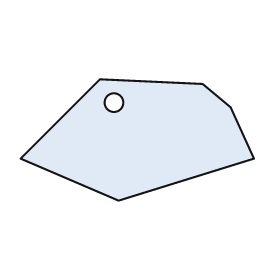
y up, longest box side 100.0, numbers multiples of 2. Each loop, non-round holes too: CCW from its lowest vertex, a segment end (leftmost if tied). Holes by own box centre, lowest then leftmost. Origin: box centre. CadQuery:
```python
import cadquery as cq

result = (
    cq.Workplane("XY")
    .moveTo(-8.0, -26.0)
    .lineTo(50.0, -8.0)
    .lineTo(40.0, 14.0)
    .lineTo(28.0, 24.0)
    .lineTo(-16.0, 26.0)
    .lineTo(-50.0, -8.0)
    .close()
    .moveTo(-10.0, 16.0)
    .circle(4.0)
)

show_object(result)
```